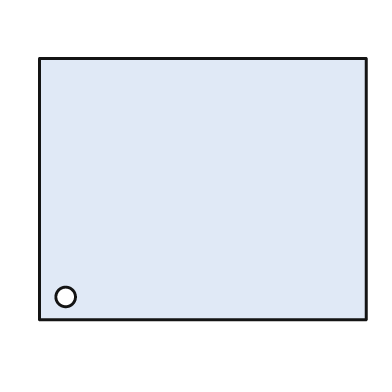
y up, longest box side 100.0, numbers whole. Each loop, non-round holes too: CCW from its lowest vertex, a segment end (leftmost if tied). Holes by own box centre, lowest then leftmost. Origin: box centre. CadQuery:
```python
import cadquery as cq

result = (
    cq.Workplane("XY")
    .moveTo(-50.0, -40.0)
    .lineTo(50.0, -40.0)
    .lineTo(50.0, 40.0)
    .lineTo(-50.0, 40.0)
    .close()
    .moveTo(-42.0, -33.0)
    .circle(3.0)
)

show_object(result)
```